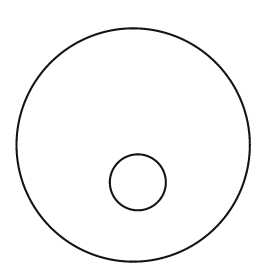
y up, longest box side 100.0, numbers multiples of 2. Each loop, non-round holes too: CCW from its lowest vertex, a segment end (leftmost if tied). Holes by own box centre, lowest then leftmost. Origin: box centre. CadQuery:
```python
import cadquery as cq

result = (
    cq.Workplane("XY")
    .moveTo(0.0, 0.0)
    .circle(50.0)
    .moveTo(2.0, -16.0)
    .circle(12.0)
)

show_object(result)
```